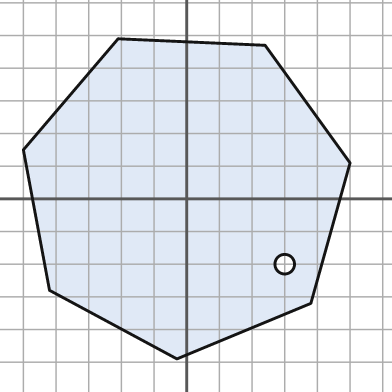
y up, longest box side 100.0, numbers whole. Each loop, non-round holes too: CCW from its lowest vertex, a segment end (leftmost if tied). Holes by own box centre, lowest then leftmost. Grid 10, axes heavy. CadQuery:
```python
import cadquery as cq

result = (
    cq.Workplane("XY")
    .moveTo(-3.0, -49.0)
    .lineTo(38.0, -32.0)
    .lineTo(50.0, 11.0)
    .lineTo(24.0, 47.0)
    .lineTo(-21.0, 49.0)
    .lineTo(-50.0, 15.0)
    .lineTo(-42.0, -28.0)
    .close()
    .moveTo(30.0, -20.0)
    .circle(3.0)
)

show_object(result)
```